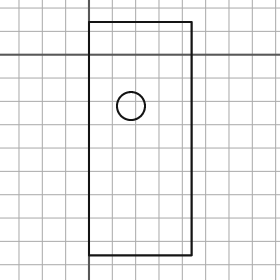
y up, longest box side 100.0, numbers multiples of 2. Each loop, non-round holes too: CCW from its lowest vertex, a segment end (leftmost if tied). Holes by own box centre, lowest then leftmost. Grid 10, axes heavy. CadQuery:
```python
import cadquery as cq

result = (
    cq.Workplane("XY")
    .moveTo(0.0, -86.0)
    .lineTo(44.0, -86.0)
    .lineTo(44.0, 14.0)
    .lineTo(0.0, 14.0)
    .close()
    .moveTo(18.0, -22.0)
    .circle(6.0)
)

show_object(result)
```